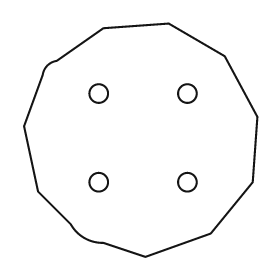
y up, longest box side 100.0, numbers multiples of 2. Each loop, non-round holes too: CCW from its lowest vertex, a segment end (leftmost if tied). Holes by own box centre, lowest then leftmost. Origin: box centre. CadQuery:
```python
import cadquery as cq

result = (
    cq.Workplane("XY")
    .moveTo(2.0, -50.0)
    .lineTo(30.0, -40.0)
    .lineTo(48.0, -18.0)
    .lineTo(50.0, 10.0)
    .lineTo(36.0, 36.0)
    .lineTo(12.0, 50.0)
    .lineTo(-16.0, 48.0)
    .lineTo(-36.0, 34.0)
    .threePointArc((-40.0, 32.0), (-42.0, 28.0))
    .lineTo(-50.0, 6.0)
    .lineTo(-44.0, -22.0)
    .lineTo(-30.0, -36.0)
    .threePointArc((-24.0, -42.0), (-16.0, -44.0))
    .close()
    .moveTo(-18.0, -18.0)
    .circle(4.0)
    .moveTo(20.0, -18.0)
    .circle(4.0)
    .moveTo(-18.0, 20.0)
    .circle(4.0)
    .moveTo(20.0, 20.0)
    .circle(4.0)
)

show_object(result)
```